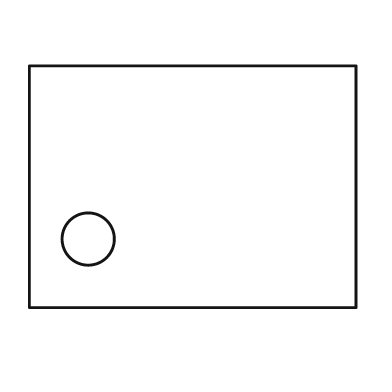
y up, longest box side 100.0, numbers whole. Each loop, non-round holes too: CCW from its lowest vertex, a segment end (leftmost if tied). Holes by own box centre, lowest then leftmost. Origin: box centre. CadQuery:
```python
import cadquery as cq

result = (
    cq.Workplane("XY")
    .moveTo(-50.0, -37.0)
    .lineTo(50.0, -37.0)
    .lineTo(50.0, 37.0)
    .lineTo(-50.0, 37.0)
    .close()
    .moveTo(-32.0, -16.0)
    .circle(8.0)
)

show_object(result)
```